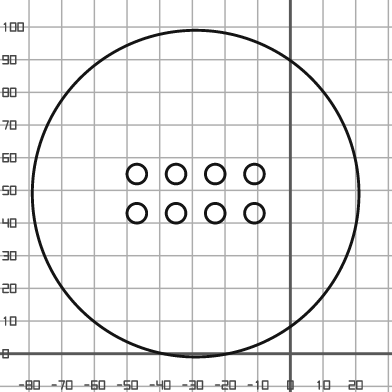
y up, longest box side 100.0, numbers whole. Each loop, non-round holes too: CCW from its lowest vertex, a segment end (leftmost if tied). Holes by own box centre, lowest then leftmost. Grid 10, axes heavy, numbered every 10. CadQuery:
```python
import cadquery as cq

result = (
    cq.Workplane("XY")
    .moveTo(-29.0, 49.0)
    .circle(50.0)
    .moveTo(-47.0, 43.0)
    .circle(3.0)
    .moveTo(-35.0, 43.0)
    .circle(3.0)
    .moveTo(-23.0, 43.0)
    .circle(3.0)
    .moveTo(-11.0, 43.0)
    .circle(3.0)
    .moveTo(-47.0, 55.0)
    .circle(3.0)
    .moveTo(-35.0, 55.0)
    .circle(3.0)
    .moveTo(-23.0, 55.0)
    .circle(3.0)
    .moveTo(-11.0, 55.0)
    .circle(3.0)
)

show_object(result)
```